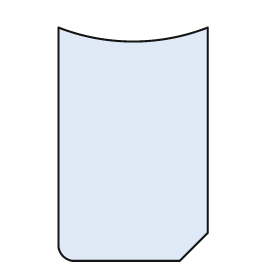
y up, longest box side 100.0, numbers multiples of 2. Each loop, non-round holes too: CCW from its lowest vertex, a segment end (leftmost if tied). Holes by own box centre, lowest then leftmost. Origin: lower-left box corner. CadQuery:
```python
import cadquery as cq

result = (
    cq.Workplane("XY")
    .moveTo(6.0, 0.0)
    .lineTo(52.0, 0.0)
    .lineTo(64.0, 12.0)
    .lineTo(64.0, 100.0)
    .threePointArc((32.0, 94.0), (0.0, 100.0))
    .lineTo(0.0, 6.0)
    .threePointArc((2.0, 2.0), (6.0, 0.0))
    .close()
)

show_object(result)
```